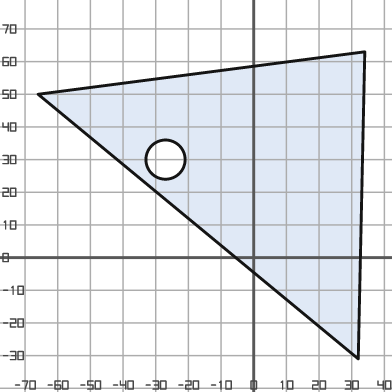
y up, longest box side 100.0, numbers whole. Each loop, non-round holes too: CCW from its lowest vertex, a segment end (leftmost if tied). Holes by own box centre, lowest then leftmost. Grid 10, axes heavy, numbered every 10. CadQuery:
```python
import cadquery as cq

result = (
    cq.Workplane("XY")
    .moveTo(32.0, -31.0)
    .lineTo(34.0, 63.0)
    .lineTo(-66.0, 50.0)
    .close()
    .moveTo(-27.0, 30.0)
    .circle(6.0)
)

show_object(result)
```